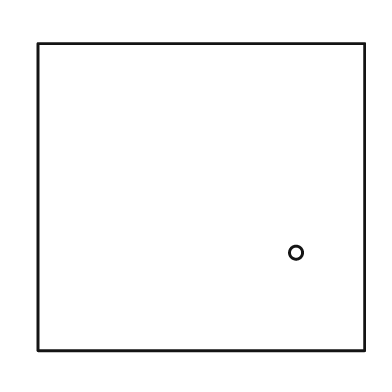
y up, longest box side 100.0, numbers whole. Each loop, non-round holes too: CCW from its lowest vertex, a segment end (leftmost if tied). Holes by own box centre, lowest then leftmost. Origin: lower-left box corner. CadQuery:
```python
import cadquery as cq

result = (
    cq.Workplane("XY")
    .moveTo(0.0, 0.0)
    .lineTo(100.0, 0.0)
    .lineTo(100.0, 94.0)
    .lineTo(0.0, 94.0)
    .close()
    .moveTo(79.0, 30.0)
    .circle(2.0)
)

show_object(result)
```